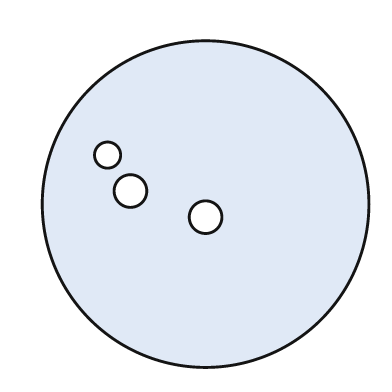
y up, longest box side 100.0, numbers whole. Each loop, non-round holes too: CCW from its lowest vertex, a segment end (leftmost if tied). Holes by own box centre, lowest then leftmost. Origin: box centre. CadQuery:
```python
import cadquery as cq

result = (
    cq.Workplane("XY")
    .moveTo(0.0, 0.0)
    .circle(50.0)
    .moveTo(0.0, -4.0)
    .circle(5.0)
    .moveTo(-23.0, 4.0)
    .circle(5.0)
    .moveTo(-30.0, 15.0)
    .circle(4.0)
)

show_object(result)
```